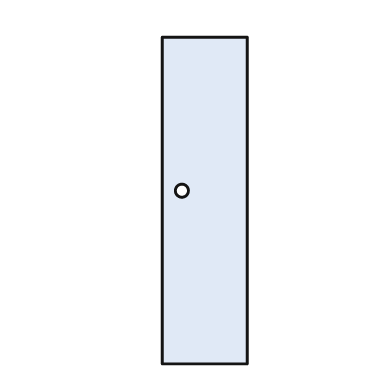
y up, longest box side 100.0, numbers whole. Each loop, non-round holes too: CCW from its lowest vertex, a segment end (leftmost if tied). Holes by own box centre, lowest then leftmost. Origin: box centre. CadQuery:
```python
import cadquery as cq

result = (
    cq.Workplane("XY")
    .moveTo(-13.0, -50.0)
    .lineTo(13.0, -50.0)
    .lineTo(13.0, 50.0)
    .lineTo(-13.0, 50.0)
    .close()
    .moveTo(-7.0, 3.0)
    .circle(2.0)
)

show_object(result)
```